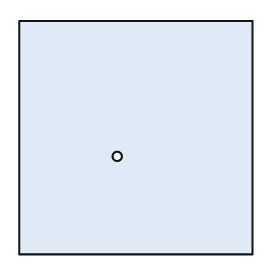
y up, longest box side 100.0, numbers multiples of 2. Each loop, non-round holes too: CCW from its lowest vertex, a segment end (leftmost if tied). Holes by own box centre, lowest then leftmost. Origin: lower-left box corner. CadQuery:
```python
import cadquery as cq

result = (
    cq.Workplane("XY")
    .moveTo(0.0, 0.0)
    .lineTo(100.0, 0.0)
    .lineTo(100.0, 100.0)
    .lineTo(0.0, 100.0)
    .close()
    .moveTo(42.0, 42.0)
    .circle(2.0)
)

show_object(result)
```